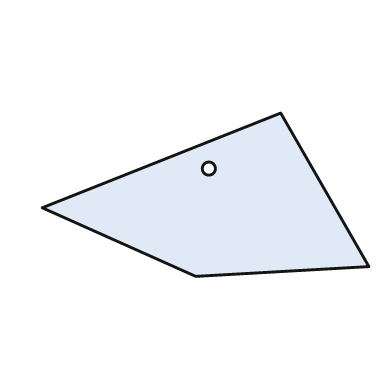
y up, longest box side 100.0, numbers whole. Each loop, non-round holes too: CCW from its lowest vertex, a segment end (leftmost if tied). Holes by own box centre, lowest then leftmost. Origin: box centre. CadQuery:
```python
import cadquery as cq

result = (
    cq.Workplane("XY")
    .moveTo(-3.0, -25.0)
    .lineTo(50.0, -22.0)
    .lineTo(23.0, 25.0)
    .lineTo(-50.0, -4.0)
    .close()
    .moveTo(1.0, 8.0)
    .circle(2.0)
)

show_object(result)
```